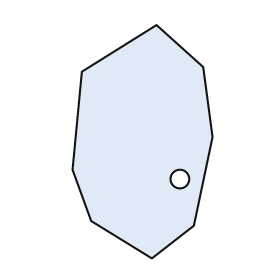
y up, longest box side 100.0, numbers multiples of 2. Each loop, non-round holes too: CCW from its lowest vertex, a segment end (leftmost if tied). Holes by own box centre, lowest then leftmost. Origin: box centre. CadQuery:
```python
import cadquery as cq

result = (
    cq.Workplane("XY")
    .moveTo(4.0, -50.0)
    .lineTo(22.0, -36.0)
    .lineTo(30.0, 2.0)
    .lineTo(26.0, 32.0)
    .lineTo(6.0, 50.0)
    .lineTo(-26.0, 30.0)
    .lineTo(-30.0, -12.0)
    .lineTo(-22.0, -34.0)
    .close()
    .moveTo(16.0, -16.0)
    .circle(4.0)
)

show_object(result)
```